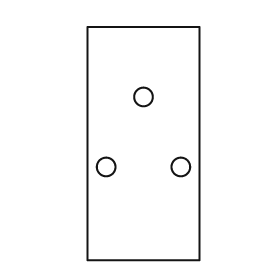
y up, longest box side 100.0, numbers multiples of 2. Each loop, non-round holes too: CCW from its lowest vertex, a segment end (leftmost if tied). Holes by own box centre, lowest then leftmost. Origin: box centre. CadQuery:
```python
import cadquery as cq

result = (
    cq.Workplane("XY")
    .moveTo(-24.0, -50.0)
    .lineTo(24.0, -50.0)
    .lineTo(24.0, 50.0)
    .lineTo(-24.0, 50.0)
    .close()
    .moveTo(-16.0, -10.0)
    .circle(4.0)
    .moveTo(16.0, -10.0)
    .circle(4.0)
    .moveTo(0.0, 20.0)
    .circle(4.0)
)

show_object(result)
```